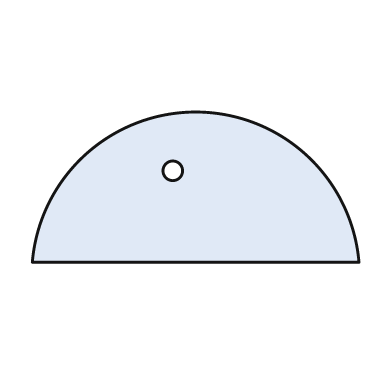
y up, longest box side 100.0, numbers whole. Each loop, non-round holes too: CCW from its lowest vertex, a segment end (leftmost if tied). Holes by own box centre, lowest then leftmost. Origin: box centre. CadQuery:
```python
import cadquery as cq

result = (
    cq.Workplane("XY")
    .moveTo(-50.0, -23.0)
    .lineTo(50.0, -23.0)
    .threePointArc((0.0, 23.0), (-50.0, -23.0))
    .close()
    .moveTo(-7.0, 5.0)
    .circle(3.0)
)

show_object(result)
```